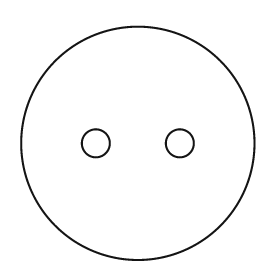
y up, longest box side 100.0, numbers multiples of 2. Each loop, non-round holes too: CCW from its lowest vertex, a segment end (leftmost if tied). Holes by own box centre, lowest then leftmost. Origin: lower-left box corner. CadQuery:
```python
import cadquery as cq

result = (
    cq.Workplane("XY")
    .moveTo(50.0, 50.0)
    .circle(50.0)
    .moveTo(32.0, 50.0)
    .circle(6.0)
    .moveTo(68.0, 50.0)
    .circle(6.0)
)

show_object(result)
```